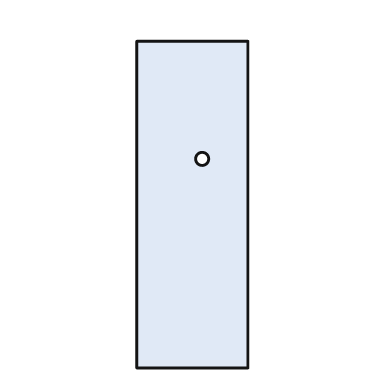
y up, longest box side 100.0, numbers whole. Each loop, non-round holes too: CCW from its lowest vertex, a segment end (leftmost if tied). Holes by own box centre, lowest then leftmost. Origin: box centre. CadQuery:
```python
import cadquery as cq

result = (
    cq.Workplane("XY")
    .moveTo(-17.0, -50.0)
    .lineTo(17.0, -50.0)
    .lineTo(17.0, 50.0)
    .lineTo(-17.0, 50.0)
    .close()
    .moveTo(3.0, 14.0)
    .circle(2.0)
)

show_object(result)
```